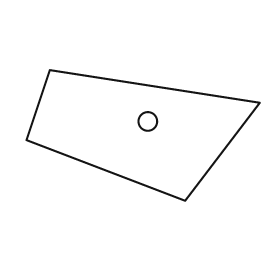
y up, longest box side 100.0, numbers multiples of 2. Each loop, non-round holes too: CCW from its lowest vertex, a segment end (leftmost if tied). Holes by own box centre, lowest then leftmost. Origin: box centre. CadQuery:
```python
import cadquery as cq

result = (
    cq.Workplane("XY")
    .moveTo(18.0, -28.0)
    .lineTo(50.0, 14.0)
    .lineTo(-40.0, 28.0)
    .lineTo(-50.0, -2.0)
    .close()
    .moveTo(2.0, 6.0)
    .circle(4.0)
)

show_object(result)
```